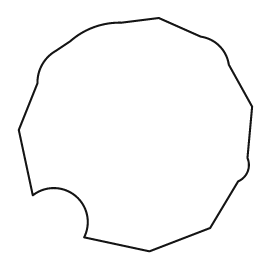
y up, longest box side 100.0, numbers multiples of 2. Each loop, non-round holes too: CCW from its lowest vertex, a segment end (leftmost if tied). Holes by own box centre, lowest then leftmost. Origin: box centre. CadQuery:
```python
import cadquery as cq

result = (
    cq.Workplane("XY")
    .moveTo(6.0, -50.0)
    .lineTo(32.0, -40.0)
    .lineTo(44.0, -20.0)
    .threePointArc((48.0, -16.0), (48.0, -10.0))
    .lineTo(50.0, 12.0)
    .lineTo(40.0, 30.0)
    .threePointArc((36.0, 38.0), (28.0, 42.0))
    .lineTo(10.0, 50.0)
    .lineTo(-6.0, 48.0)
    .threePointArc((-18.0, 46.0), (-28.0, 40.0))
    .lineTo(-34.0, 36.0)
    .threePointArc((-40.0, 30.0), (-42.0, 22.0))
    .lineTo(-50.0, 2.0)
    .lineTo(-44.0, -26.0)
    .threePointArc((-26.0, -26.0), (-22.0, -44.0))
    .close()
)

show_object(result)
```